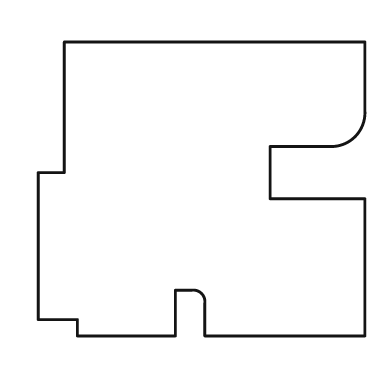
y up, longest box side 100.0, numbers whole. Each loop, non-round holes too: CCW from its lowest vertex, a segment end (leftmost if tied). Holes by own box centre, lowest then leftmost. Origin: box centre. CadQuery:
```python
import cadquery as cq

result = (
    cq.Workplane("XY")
    .moveTo(-38.0, -45.0)
    .lineTo(-8.0, -45.0)
    .lineTo(-8.0, -31.0)
    .lineTo(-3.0, -31.0)
    .threePointArc((0.0, -32.0), (1.0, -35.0))
    .lineTo(1.0, -45.0)
    .lineTo(50.0, -45.0)
    .lineTo(50.0, -3.0)
    .lineTo(21.0, -3.0)
    .lineTo(21.0, 13.0)
    .lineTo(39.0, 13.0)
    .threePointArc((47.0, 16.0), (50.0, 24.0))
    .lineTo(50.0, 45.0)
    .lineTo(-42.0, 45.0)
    .lineTo(-42.0, 5.0)
    .lineTo(-50.0, 5.0)
    .lineTo(-50.0, -40.0)
    .lineTo(-38.0, -40.0)
    .close()
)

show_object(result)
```